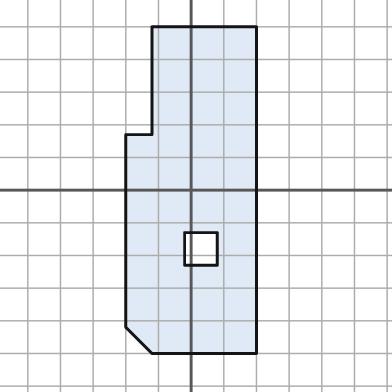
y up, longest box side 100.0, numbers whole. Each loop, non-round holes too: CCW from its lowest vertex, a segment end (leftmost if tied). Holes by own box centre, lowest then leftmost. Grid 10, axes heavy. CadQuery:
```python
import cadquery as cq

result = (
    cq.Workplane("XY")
    .moveTo(-12.0, -50.0)
    .lineTo(20.0, -50.0)
    .lineTo(20.0, 50.0)
    .lineTo(-12.0, 50.0)
    .lineTo(-12.0, 17.0)
    .lineTo(-20.0, 17.0)
    .lineTo(-20.0, -42.0)
    .close()
    .moveTo(-2.0, -23.0)
    .lineTo(8.0, -23.0)
    .lineTo(8.0, -13.0)
    .lineTo(-2.0, -13.0)
    .close()
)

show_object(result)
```